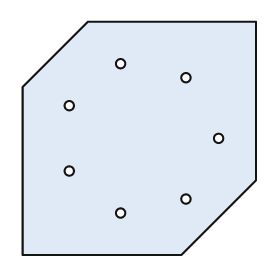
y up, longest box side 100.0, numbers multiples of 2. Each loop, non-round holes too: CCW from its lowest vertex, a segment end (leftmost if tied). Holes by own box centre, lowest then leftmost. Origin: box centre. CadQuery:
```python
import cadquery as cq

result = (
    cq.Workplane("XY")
    .moveTo(-50.0, -50.0)
    .lineTo(18.0, -50.0)
    .lineTo(50.0, -18.0)
    .lineTo(50.0, 50.0)
    .lineTo(-22.0, 50.0)
    .lineTo(-50.0, 22.0)
    .close()
    .moveTo(-8.0, -32.0)
    .circle(2.0)
    .moveTo(20.0, -26.0)
    .circle(2.0)
    .moveTo(-30.0, -14.0)
    .circle(2.0)
    .moveTo(34.0, 0.0)
    .circle(2.0)
    .moveTo(-30.0, 14.0)
    .circle(2.0)
    .moveTo(20.0, 26.0)
    .circle(2.0)
    .moveTo(-8.0, 32.0)
    .circle(2.0)
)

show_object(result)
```